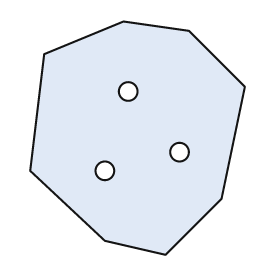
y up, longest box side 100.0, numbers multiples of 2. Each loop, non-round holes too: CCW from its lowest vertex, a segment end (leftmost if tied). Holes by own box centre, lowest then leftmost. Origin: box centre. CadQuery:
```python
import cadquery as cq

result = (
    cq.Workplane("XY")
    .moveTo(12.0, -50.0)
    .lineTo(36.0, -26.0)
    .lineTo(46.0, 22.0)
    .lineTo(22.0, 46.0)
    .lineTo(-6.0, 50.0)
    .lineTo(-40.0, 36.0)
    .lineTo(-46.0, -14.0)
    .lineTo(-14.0, -44.0)
    .close()
    .moveTo(-14.0, -14.0)
    .circle(4.0)
    .moveTo(18.0, -6.0)
    .circle(4.0)
    .moveTo(-4.0, 20.0)
    .circle(4.0)
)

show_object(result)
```